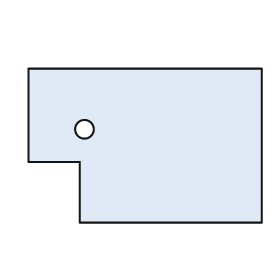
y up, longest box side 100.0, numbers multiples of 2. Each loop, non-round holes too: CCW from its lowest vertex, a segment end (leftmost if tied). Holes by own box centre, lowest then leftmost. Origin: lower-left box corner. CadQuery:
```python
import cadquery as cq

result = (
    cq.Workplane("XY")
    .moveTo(22.0, 0.0)
    .lineTo(100.0, 0.0)
    .lineTo(100.0, 66.0)
    .lineTo(0.0, 66.0)
    .lineTo(0.0, 26.0)
    .lineTo(22.0, 26.0)
    .close()
    .moveTo(24.0, 40.0)
    .circle(4.0)
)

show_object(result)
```